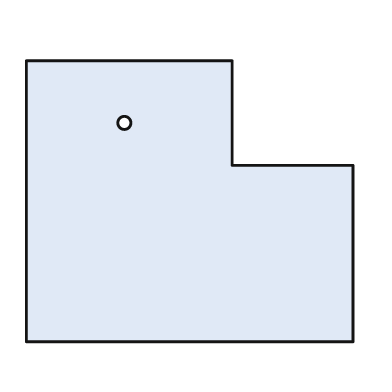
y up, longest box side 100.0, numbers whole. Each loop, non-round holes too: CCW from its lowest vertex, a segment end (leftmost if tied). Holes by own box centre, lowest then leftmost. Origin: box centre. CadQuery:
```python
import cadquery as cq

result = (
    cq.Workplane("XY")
    .moveTo(-50.0, -43.0)
    .lineTo(50.0, -43.0)
    .lineTo(50.0, 11.0)
    .lineTo(13.0, 11.0)
    .lineTo(13.0, 43.0)
    .lineTo(-50.0, 43.0)
    .close()
    .moveTo(-20.0, 24.0)
    .circle(2.0)
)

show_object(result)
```